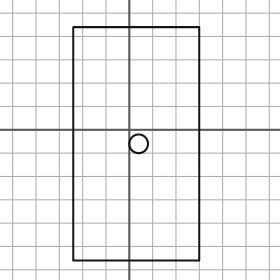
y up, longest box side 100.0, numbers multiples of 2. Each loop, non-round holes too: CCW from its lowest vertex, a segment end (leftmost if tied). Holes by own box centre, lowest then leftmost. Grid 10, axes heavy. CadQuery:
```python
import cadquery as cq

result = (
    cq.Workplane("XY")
    .moveTo(-24.0, -56.0)
    .lineTo(30.0, -56.0)
    .lineTo(30.0, 44.0)
    .lineTo(-24.0, 44.0)
    .close()
    .moveTo(4.0, -6.0)
    .circle(4.0)
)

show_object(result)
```